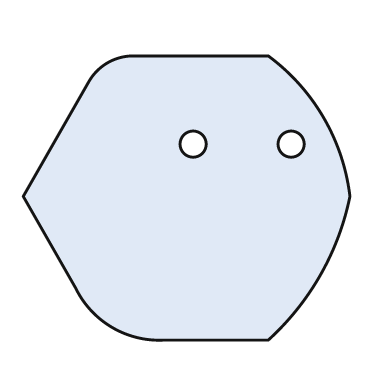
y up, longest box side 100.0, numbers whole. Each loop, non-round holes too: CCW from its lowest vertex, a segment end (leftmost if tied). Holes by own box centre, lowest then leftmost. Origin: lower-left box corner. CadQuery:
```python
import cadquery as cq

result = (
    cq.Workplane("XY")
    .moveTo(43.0, 0.0)
    .lineTo(75.0, 0.0)
    .threePointArc((91.0, 20.0), (100.0, 44.0))
    .threePointArc((92.0, 68.0), (75.0, 87.0))
    .lineTo(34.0, 87.0)
    .threePointArc((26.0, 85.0), (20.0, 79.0))
    .lineTo(0.0, 44.0)
    .lineTo(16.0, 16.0)
    .threePointArc((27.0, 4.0), (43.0, 0.0))
    .close()
    .moveTo(52.0, 60.0)
    .circle(4.0)
    .moveTo(82.0, 60.0)
    .circle(4.0)
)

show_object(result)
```